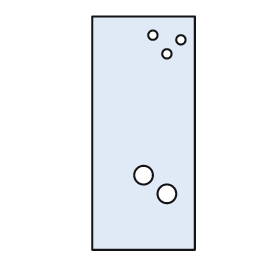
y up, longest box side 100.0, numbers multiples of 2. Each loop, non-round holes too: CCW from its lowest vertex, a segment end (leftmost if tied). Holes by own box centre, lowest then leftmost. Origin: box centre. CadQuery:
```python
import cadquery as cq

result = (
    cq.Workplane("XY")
    .moveTo(-22.0, -50.0)
    .lineTo(22.0, -50.0)
    .lineTo(22.0, 50.0)
    .lineTo(-22.0, 50.0)
    .close()
    .moveTo(10.0, -26.0)
    .circle(4.0)
    .moveTo(0.0, -18.0)
    .circle(4.0)
    .moveTo(10.0, 34.0)
    .circle(2.0)
    .moveTo(16.0, 40.0)
    .circle(2.0)
    .moveTo(4.0, 42.0)
    .circle(2.0)
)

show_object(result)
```